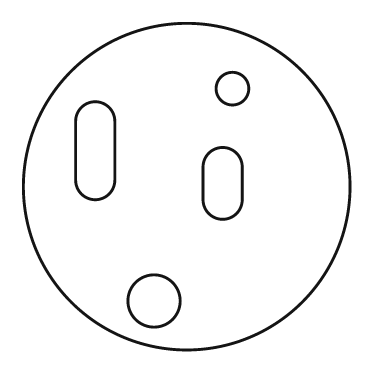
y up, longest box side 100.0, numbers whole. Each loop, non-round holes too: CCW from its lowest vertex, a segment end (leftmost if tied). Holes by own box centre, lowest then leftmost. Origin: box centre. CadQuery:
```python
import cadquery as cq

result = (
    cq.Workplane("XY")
    .moveTo(0.0, 0.0)
    .circle(50.0)
    .moveTo(-10.0, -35.0)
    .circle(8.0)
    .moveTo(5.0, -4.0)
    .threePointArc((11.0, -10.0), (17.0, -4.0))
    .lineTo(17.0, 6.0)
    .threePointArc((11.0, 12.0), (5.0, 6.0))
    .close()
    .moveTo(-34.0, 2.0)
    .threePointArc((-28.0, -4.0), (-22.0, 2.0))
    .lineTo(-22.0, 20.0)
    .threePointArc((-28.0, 26.0), (-34.0, 20.0))
    .close()
    .moveTo(14.0, 30.0)
    .circle(5.0)
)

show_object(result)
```